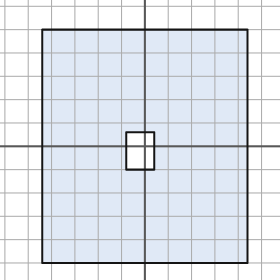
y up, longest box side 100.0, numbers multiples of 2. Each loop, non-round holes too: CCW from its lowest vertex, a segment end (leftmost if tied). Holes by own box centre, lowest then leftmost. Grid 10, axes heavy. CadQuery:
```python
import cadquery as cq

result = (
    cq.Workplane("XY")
    .moveTo(-44.0, -50.0)
    .lineTo(44.0, -50.0)
    .lineTo(44.0, 50.0)
    .lineTo(-44.0, 50.0)
    .close()
    .moveTo(-8.0, -10.0)
    .lineTo(4.0, -10.0)
    .lineTo(4.0, 6.0)
    .lineTo(-8.0, 6.0)
    .close()
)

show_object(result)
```